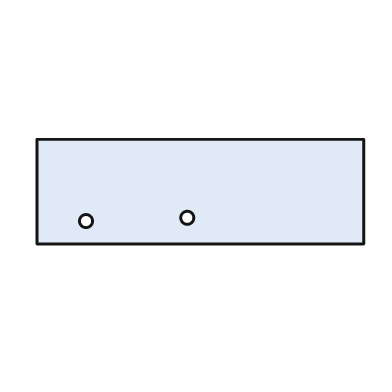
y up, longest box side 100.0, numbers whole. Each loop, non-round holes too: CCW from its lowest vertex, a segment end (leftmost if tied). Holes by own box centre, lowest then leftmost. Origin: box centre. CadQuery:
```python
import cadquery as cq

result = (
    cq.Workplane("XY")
    .moveTo(-50.0, -16.0)
    .lineTo(50.0, -16.0)
    .lineTo(50.0, 16.0)
    .lineTo(-50.0, 16.0)
    .close()
    .moveTo(-35.0, -9.0)
    .circle(2.0)
    .moveTo(-4.0, -8.0)
    .circle(2.0)
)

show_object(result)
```